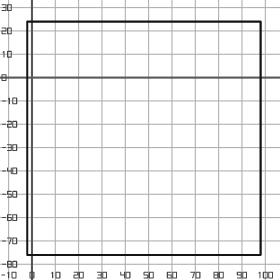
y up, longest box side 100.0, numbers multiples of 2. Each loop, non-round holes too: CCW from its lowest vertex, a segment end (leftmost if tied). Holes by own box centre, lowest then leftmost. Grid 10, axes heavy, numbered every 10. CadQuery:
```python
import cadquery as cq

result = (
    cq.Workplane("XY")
    .moveTo(-2.0, -76.0)
    .lineTo(98.0, -76.0)
    .lineTo(98.0, 24.0)
    .lineTo(-2.0, 24.0)
    .close()
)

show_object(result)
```